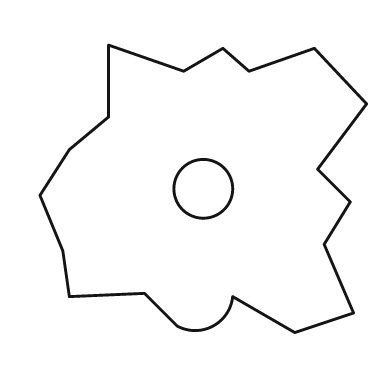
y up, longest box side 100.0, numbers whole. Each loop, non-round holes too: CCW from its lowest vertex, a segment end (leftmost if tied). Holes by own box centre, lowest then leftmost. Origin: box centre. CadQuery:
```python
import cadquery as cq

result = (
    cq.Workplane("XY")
    .moveTo(28.0, -44.0)
    .lineTo(46.0, -38.0)
    .lineTo(37.0, -17.0)
    .lineTo(45.0, -4.0)
    .lineTo(35.0, 6.0)
    .lineTo(50.0, 26.0)
    .lineTo(34.0, 43.0)
    .lineTo(14.0, 36.0)
    .lineTo(6.0, 43.0)
    .lineTo(-6.0, 36.0)
    .lineTo(-29.0, 44.0)
    .lineTo(-29.0, 22.0)
    .lineTo(-41.0, 12.0)
    .lineTo(-50.0, -2.0)
    .lineTo(-43.0, -19.0)
    .lineTo(-41.0, -33.0)
    .lineTo(-18.0, -32.0)
    .lineTo(-8.0, -42.0)
    .threePointArc((3.0, -42.0), (9.0, -33.0))
    .close()
    .moveTo(0.0, 0.0)
    .circle(9.0)
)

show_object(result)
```